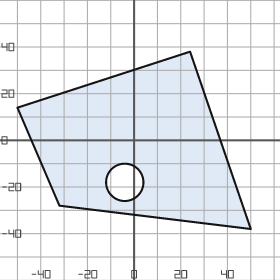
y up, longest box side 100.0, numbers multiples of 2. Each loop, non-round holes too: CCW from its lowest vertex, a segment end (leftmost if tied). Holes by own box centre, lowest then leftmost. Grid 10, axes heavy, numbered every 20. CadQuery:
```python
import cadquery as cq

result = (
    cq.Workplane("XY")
    .moveTo(50.0, -38.0)
    .lineTo(24.0, 38.0)
    .lineTo(-50.0, 14.0)
    .lineTo(-32.0, -28.0)
    .close()
    .moveTo(-4.0, -18.0)
    .circle(8.0)
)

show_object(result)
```